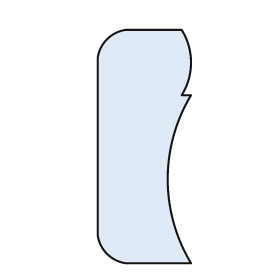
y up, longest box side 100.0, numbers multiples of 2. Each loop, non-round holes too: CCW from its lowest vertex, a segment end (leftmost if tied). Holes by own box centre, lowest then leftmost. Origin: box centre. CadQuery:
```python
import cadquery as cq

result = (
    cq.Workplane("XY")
    .moveTo(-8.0, -50.0)
    .lineTo(20.0, -50.0)
    .threePointArc((10.0, -14.0), (20.0, 22.0))
    .lineTo(16.0, 22.0)
    .threePointArc((20.0, 36.0), (16.0, 50.0))
    .lineTo(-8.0, 50.0)
    .threePointArc((-16.0, 46.0), (-20.0, 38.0))
    .lineTo(-20.0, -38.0)
    .threePointArc((-16.0, -46.0), (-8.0, -50.0))
    .close()
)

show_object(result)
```